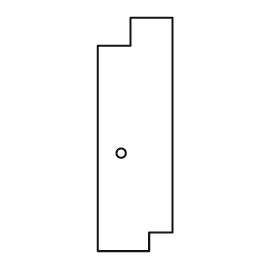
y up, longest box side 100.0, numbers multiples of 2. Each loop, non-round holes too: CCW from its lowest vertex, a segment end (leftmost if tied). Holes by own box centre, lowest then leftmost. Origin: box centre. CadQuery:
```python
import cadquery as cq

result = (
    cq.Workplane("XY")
    .moveTo(-16.0, -50.0)
    .lineTo(6.0, -50.0)
    .lineTo(6.0, -42.0)
    .lineTo(16.0, -42.0)
    .lineTo(16.0, 50.0)
    .lineTo(-2.0, 50.0)
    .lineTo(-2.0, 38.0)
    .lineTo(-16.0, 38.0)
    .close()
    .moveTo(-6.0, -8.0)
    .circle(2.0)
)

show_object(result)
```